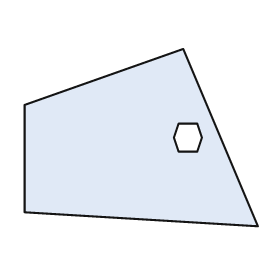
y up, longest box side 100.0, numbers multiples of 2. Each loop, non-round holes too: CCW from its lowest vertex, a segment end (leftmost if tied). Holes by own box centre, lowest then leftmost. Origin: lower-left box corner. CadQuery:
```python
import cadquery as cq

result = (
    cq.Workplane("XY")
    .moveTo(100.0, 0.0)
    .lineTo(68.0, 76.0)
    .lineTo(0.0, 52.0)
    .lineTo(0.0, 6.0)
    .close()
    .moveTo(66.0, 32.0)
    .lineTo(74.0, 32.0)
    .lineTo(76.0, 38.0)
    .lineTo(74.0, 44.0)
    .lineTo(66.0, 44.0)
    .lineTo(64.0, 38.0)
    .close()
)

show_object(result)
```